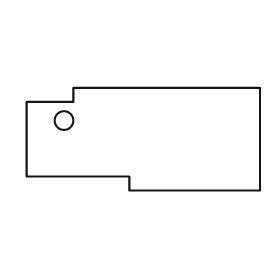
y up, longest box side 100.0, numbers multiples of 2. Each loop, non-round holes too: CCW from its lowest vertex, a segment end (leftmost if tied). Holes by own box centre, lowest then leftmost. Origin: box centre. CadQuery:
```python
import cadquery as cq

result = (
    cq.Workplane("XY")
    .moveTo(-6.0, -22.0)
    .lineTo(50.0, -22.0)
    .lineTo(50.0, 22.0)
    .lineTo(-30.0, 22.0)
    .lineTo(-30.0, 16.0)
    .lineTo(-50.0, 16.0)
    .lineTo(-50.0, -16.0)
    .lineTo(-6.0, -16.0)
    .close()
    .moveTo(-34.0, 8.0)
    .circle(4.0)
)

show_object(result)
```